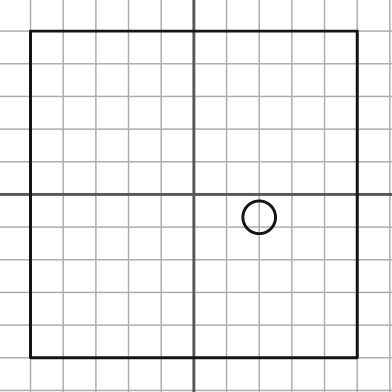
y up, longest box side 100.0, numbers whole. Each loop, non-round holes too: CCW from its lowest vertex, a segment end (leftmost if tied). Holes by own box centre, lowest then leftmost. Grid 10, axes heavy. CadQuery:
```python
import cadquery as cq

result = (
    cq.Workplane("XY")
    .moveTo(-50.0, -50.0)
    .lineTo(50.0, -50.0)
    .lineTo(50.0, 50.0)
    .lineTo(-50.0, 50.0)
    .close()
    .moveTo(20.0, -7.0)
    .circle(5.0)
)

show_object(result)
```